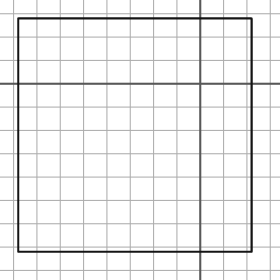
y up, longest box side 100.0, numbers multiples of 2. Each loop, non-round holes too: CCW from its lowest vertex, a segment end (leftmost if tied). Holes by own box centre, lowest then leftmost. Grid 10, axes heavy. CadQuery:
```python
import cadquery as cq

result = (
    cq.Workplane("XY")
    .moveTo(-78.0, -72.0)
    .lineTo(22.0, -72.0)
    .lineTo(22.0, 28.0)
    .lineTo(-78.0, 28.0)
    .close()
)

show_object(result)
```